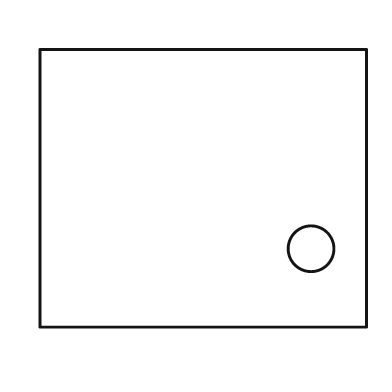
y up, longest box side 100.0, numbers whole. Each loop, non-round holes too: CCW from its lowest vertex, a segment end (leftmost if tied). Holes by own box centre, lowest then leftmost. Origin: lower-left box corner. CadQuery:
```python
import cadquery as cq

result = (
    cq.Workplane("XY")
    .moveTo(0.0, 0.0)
    .lineTo(100.0, 0.0)
    .lineTo(100.0, 85.0)
    .lineTo(0.0, 85.0)
    .close()
    .moveTo(83.0, 24.0)
    .circle(7.0)
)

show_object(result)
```